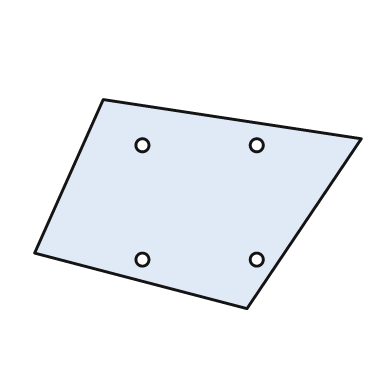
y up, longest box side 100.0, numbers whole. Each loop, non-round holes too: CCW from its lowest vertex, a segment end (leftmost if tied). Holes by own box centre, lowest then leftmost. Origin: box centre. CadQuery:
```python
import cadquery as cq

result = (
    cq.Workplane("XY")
    .moveTo(15.0, -32.0)
    .lineTo(50.0, 20.0)
    .lineTo(-29.0, 32.0)
    .lineTo(-50.0, -15.0)
    .close()
    .moveTo(-17.0, -17.0)
    .circle(2.0)
    .moveTo(18.0, -17.0)
    .circle(2.0)
    .moveTo(-17.0, 18.0)
    .circle(2.0)
    .moveTo(18.0, 18.0)
    .circle(2.0)
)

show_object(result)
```